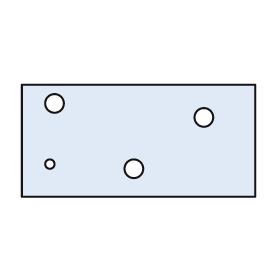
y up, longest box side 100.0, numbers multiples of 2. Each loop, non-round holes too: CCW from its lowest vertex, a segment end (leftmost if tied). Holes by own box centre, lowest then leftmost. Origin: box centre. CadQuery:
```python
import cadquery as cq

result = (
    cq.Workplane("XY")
    .moveTo(-50.0, -24.0)
    .lineTo(50.0, -24.0)
    .lineTo(50.0, 24.0)
    .lineTo(-50.0, 24.0)
    .close()
    .moveTo(-2.0, -12.0)
    .circle(4.0)
    .moveTo(-38.0, -10.0)
    .circle(2.0)
    .moveTo(28.0, 10.0)
    .circle(4.0)
    .moveTo(-36.0, 16.0)
    .circle(4.0)
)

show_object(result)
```